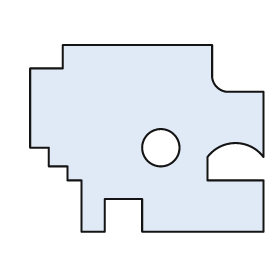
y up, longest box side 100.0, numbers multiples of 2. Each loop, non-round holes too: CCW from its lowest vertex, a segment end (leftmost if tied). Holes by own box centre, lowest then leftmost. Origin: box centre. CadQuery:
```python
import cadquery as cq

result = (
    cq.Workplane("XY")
    .moveTo(-28.0, -40.0)
    .lineTo(-18.0, -40.0)
    .lineTo(-18.0, -26.0)
    .lineTo(-2.0, -26.0)
    .lineTo(-2.0, -40.0)
    .lineTo(50.0, -40.0)
    .lineTo(50.0, -18.0)
    .lineTo(26.0, -18.0)
    .lineTo(26.0, -8.0)
    .threePointArc((38.0, -2.0), (50.0, -8.0))
    .lineTo(50.0, 20.0)
    .lineTo(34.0, 20.0)
    .threePointArc((30.0, 22.0), (28.0, 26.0))
    .lineTo(28.0, 40.0)
    .lineTo(-36.0, 40.0)
    .lineTo(-36.0, 30.0)
    .lineTo(-50.0, 30.0)
    .lineTo(-50.0, -4.0)
    .lineTo(-42.0, -4.0)
    .lineTo(-42.0, -12.0)
    .lineTo(-34.0, -12.0)
    .lineTo(-34.0, -18.0)
    .lineTo(-28.0, -18.0)
    .close()
    .moveTo(6.0, -4.0)
    .circle(8.0)
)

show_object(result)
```